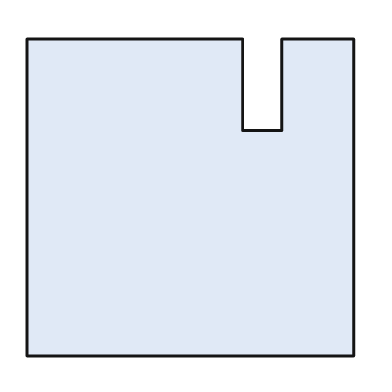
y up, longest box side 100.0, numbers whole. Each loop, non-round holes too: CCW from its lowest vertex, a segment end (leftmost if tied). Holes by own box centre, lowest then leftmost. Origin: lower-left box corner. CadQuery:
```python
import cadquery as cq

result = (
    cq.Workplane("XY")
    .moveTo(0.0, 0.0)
    .lineTo(100.0, 0.0)
    .lineTo(100.0, 97.0)
    .lineTo(78.0, 97.0)
    .lineTo(78.0, 69.0)
    .lineTo(66.0, 69.0)
    .lineTo(66.0, 97.0)
    .lineTo(0.0, 97.0)
    .close()
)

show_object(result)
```